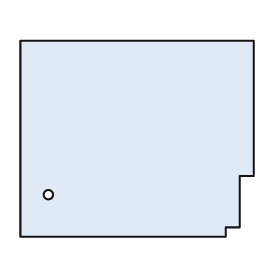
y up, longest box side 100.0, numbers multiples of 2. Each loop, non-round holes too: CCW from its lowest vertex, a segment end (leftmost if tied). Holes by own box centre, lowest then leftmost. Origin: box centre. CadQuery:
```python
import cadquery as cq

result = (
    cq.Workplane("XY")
    .moveTo(-50.0, -42.0)
    .lineTo(38.0, -42.0)
    .lineTo(38.0, -38.0)
    .lineTo(44.0, -38.0)
    .lineTo(44.0, -16.0)
    .lineTo(50.0, -16.0)
    .lineTo(50.0, 42.0)
    .lineTo(-50.0, 42.0)
    .close()
    .moveTo(-38.0, -24.0)
    .circle(2.0)
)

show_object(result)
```